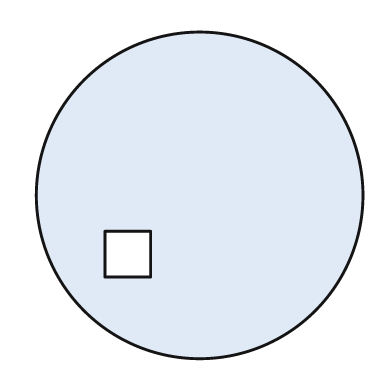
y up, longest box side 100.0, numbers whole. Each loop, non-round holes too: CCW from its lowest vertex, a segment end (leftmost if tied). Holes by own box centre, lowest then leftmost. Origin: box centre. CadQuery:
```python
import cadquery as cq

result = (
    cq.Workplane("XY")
    .moveTo(0.0, 0.0)
    .circle(50.0)
    .moveTo(-29.0, -25.0)
    .lineTo(-15.0, -25.0)
    .lineTo(-15.0, -11.0)
    .lineTo(-29.0, -11.0)
    .close()
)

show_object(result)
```